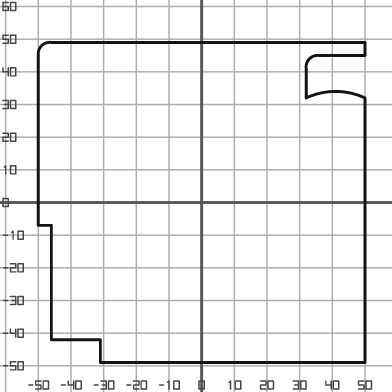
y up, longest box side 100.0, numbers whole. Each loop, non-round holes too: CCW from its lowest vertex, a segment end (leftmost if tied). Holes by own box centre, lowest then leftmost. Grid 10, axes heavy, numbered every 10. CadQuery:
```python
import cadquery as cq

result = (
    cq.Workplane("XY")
    .moveTo(-31.0, -49.0)
    .lineTo(50.0, -49.0)
    .lineTo(50.0, 32.0)
    .threePointArc((41.0, 34.0), (32.0, 32.0))
    .lineTo(32.0, 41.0)
    .threePointArc((33.0, 44.0), (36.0, 45.0))
    .lineTo(50.0, 45.0)
    .lineTo(50.0, 49.0)
    .lineTo(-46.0, 49.0)
    .threePointArc((-49.0, 48.0), (-50.0, 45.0))
    .lineTo(-50.0, -7.0)
    .lineTo(-46.0, -7.0)
    .lineTo(-46.0, -42.0)
    .lineTo(-31.0, -42.0)
    .close()
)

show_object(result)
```